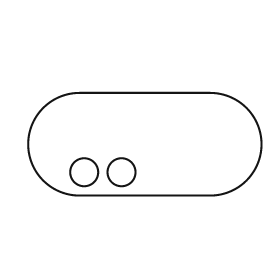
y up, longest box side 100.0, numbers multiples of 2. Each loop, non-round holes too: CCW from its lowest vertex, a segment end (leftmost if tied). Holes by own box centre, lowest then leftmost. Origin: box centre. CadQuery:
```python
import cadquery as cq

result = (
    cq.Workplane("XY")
    .moveTo(-28.0, -22.0)
    .lineTo(28.0, -22.0)
    .threePointArc((50.0, 0.0), (28.0, 22.0))
    .lineTo(-28.0, 22.0)
    .threePointArc((-50.0, 0.0), (-28.0, -22.0))
    .close()
    .moveTo(-26.0, -12.0)
    .circle(6.0)
    .moveTo(-10.0, -12.0)
    .circle(6.0)
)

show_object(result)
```